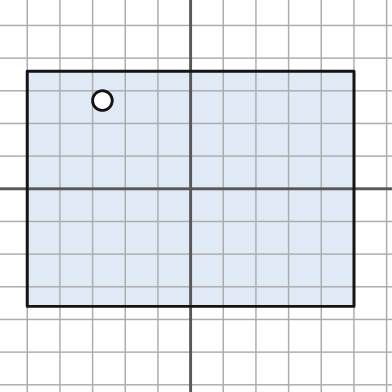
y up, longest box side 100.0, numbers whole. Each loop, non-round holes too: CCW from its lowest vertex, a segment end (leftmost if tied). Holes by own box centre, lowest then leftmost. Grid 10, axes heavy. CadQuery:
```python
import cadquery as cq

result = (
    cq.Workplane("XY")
    .moveTo(-50.0, -36.0)
    .lineTo(50.0, -36.0)
    .lineTo(50.0, 36.0)
    .lineTo(-50.0, 36.0)
    .close()
    .moveTo(-27.0, 27.0)
    .circle(3.0)
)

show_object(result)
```